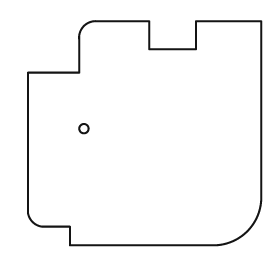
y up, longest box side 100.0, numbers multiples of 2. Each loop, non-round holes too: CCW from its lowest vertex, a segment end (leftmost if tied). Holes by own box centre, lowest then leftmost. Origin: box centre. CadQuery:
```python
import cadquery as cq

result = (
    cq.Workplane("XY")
    .moveTo(-32.0, -48.0)
    .lineTo(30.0, -48.0)
    .threePointArc((44.0, -42.0), (50.0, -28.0))
    .lineTo(50.0, 48.0)
    .lineTo(22.0, 48.0)
    .lineTo(22.0, 36.0)
    .lineTo(2.0, 36.0)
    .lineTo(2.0, 48.0)
    .lineTo(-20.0, 48.0)
    .threePointArc((-26.0, 46.0), (-28.0, 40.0))
    .lineTo(-28.0, 26.0)
    .lineTo(-50.0, 26.0)
    .lineTo(-50.0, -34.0)
    .threePointArc((-48.0, -38.0), (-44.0, -40.0))
    .lineTo(-32.0, -40.0)
    .close()
    .moveTo(-26.0, 2.0)
    .circle(2.0)
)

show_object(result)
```